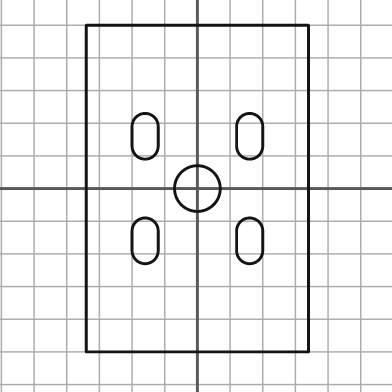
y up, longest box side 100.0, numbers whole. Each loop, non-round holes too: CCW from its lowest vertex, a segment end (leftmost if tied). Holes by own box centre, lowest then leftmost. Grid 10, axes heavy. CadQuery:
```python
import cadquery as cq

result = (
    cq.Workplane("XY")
    .moveTo(-34.0, -50.0)
    .lineTo(34.0, -50.0)
    .lineTo(34.0, 50.0)
    .lineTo(-34.0, 50.0)
    .close()
    .moveTo(-20.0, -19.0)
    .threePointArc((-16.0, -23.0), (-12.0, -19.0))
    .lineTo(-12.0, -13.0)
    .threePointArc((-16.0, -9.0), (-20.0, -13.0))
    .close()
    .moveTo(12.0, -19.0)
    .threePointArc((16.0, -23.0), (20.0, -19.0))
    .lineTo(20.0, -13.0)
    .threePointArc((16.0, -9.0), (12.0, -13.0))
    .close()
    .moveTo(0.0, 0.0)
    .circle(7.0)
    .moveTo(-20.0, 13.0)
    .threePointArc((-16.0, 9.0), (-12.0, 13.0))
    .lineTo(-12.0, 19.0)
    .threePointArc((-16.0, 23.0), (-20.0, 19.0))
    .close()
    .moveTo(12.0, 13.0)
    .threePointArc((16.0, 9.0), (20.0, 13.0))
    .lineTo(20.0, 19.0)
    .threePointArc((16.0, 23.0), (12.0, 19.0))
    .close()
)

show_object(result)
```